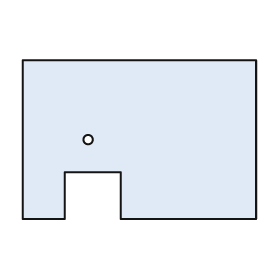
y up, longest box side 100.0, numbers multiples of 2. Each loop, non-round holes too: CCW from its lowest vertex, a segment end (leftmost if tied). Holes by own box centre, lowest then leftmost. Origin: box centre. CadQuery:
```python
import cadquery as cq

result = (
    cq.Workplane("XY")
    .moveTo(-50.0, -34.0)
    .lineTo(-32.0, -34.0)
    .lineTo(-32.0, -14.0)
    .lineTo(-8.0, -14.0)
    .lineTo(-8.0, -34.0)
    .lineTo(50.0, -34.0)
    .lineTo(50.0, 34.0)
    .lineTo(-50.0, 34.0)
    .close()
    .moveTo(-22.0, 0.0)
    .circle(2.0)
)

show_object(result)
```